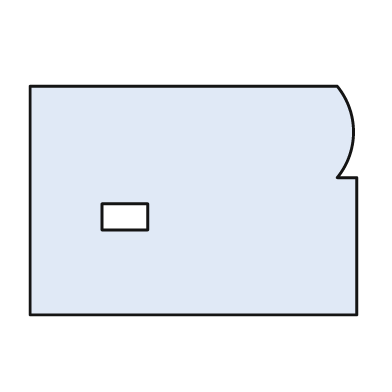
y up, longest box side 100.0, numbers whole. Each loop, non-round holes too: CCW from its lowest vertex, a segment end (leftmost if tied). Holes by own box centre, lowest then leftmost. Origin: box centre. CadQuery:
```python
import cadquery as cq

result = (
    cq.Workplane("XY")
    .moveTo(-50.0, -35.0)
    .lineTo(50.0, -35.0)
    .lineTo(50.0, 7.0)
    .lineTo(44.0, 7.0)
    .threePointArc((49.0, 21.0), (44.0, 35.0))
    .lineTo(-50.0, 35.0)
    .close()
    .moveTo(-28.0, -9.0)
    .lineTo(-14.0, -9.0)
    .lineTo(-14.0, -1.0)
    .lineTo(-28.0, -1.0)
    .close()
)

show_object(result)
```